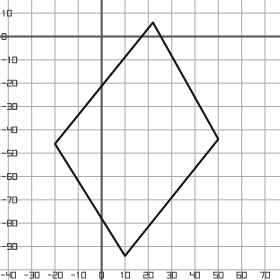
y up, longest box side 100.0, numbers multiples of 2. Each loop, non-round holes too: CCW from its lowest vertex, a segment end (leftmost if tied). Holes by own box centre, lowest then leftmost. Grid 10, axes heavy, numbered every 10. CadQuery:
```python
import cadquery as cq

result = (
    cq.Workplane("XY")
    .moveTo(10.0, -94.0)
    .lineTo(50.0, -44.0)
    .lineTo(22.0, 6.0)
    .lineTo(-20.0, -46.0)
    .close()
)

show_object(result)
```